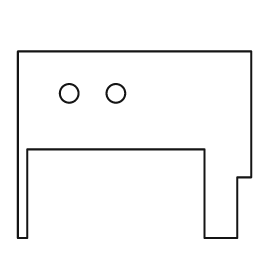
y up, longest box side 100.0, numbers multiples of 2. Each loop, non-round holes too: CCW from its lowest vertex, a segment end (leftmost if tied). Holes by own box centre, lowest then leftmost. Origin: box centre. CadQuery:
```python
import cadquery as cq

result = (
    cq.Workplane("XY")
    .moveTo(-50.0, -40.0)
    .lineTo(-46.0, -40.0)
    .lineTo(-46.0, -2.0)
    .lineTo(30.0, -2.0)
    .lineTo(30.0, -40.0)
    .lineTo(44.0, -40.0)
    .lineTo(44.0, -14.0)
    .lineTo(50.0, -14.0)
    .lineTo(50.0, 40.0)
    .lineTo(-50.0, 40.0)
    .close()
    .moveTo(-28.0, 22.0)
    .circle(4.0)
    .moveTo(-8.0, 22.0)
    .circle(4.0)
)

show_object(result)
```